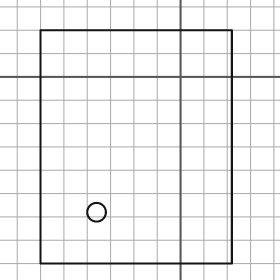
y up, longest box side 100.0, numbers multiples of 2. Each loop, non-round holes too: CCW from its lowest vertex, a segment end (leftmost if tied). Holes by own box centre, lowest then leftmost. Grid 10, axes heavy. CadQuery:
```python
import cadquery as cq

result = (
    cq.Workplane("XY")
    .moveTo(-60.0, -80.0)
    .lineTo(22.0, -80.0)
    .lineTo(22.0, 20.0)
    .lineTo(-60.0, 20.0)
    .close()
    .moveTo(-36.0, -58.0)
    .circle(4.0)
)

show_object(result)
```